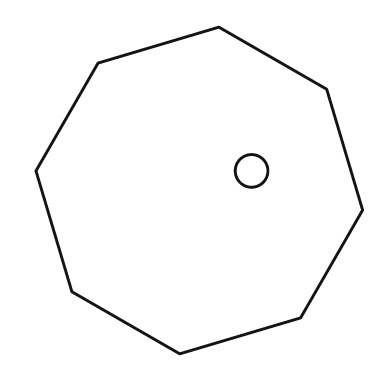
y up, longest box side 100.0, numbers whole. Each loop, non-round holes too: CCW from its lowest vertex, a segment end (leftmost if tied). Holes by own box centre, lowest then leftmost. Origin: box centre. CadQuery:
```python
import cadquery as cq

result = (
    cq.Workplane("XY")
    .moveTo(-6.0, -50.0)
    .lineTo(31.0, -39.0)
    .lineTo(50.0, -6.0)
    .lineTo(39.0, 31.0)
    .lineTo(6.0, 50.0)
    .lineTo(-31.0, 39.0)
    .lineTo(-50.0, 6.0)
    .lineTo(-39.0, -31.0)
    .close()
    .moveTo(16.0, 6.0)
    .circle(5.0)
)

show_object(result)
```